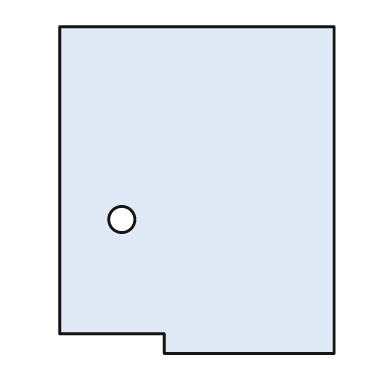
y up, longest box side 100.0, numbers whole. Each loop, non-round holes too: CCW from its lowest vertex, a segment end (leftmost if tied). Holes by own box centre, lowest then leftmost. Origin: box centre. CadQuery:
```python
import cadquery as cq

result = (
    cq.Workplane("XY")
    .moveTo(-10.0, -50.0)
    .lineTo(42.0, -50.0)
    .lineTo(42.0, 50.0)
    .lineTo(-42.0, 50.0)
    .lineTo(-42.0, -44.0)
    .lineTo(-10.0, -44.0)
    .close()
    .moveTo(-23.0, -9.0)
    .circle(4.0)
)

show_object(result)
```